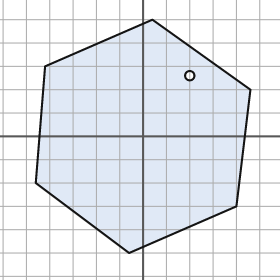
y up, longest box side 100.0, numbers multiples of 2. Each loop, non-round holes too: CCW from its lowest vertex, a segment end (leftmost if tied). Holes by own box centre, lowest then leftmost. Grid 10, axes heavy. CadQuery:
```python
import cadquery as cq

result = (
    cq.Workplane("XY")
    .moveTo(-6.0, -50.0)
    .lineTo(40.0, -30.0)
    .lineTo(46.0, 20.0)
    .lineTo(4.0, 50.0)
    .lineTo(-42.0, 30.0)
    .lineTo(-46.0, -20.0)
    .close()
    .moveTo(20.0, 26.0)
    .circle(2.0)
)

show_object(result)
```